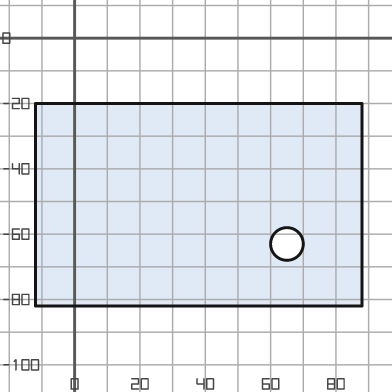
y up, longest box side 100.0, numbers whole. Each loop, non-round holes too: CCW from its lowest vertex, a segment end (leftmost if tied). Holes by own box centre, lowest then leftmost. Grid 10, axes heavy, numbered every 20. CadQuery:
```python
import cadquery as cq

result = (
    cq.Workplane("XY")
    .moveTo(-12.0, -82.0)
    .lineTo(88.0, -82.0)
    .lineTo(88.0, -20.0)
    .lineTo(-12.0, -20.0)
    .close()
    .moveTo(65.0, -63.0)
    .circle(5.0)
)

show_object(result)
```